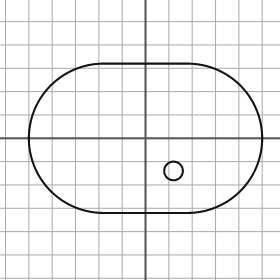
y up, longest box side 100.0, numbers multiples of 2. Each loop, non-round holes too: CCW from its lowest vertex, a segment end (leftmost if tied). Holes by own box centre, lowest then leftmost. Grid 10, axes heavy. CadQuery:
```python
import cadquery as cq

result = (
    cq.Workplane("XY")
    .moveTo(-18.0, -32.0)
    .lineTo(18.0, -32.0)
    .threePointArc((50.0, 0.0), (18.0, 32.0))
    .lineTo(-18.0, 32.0)
    .threePointArc((-50.0, 0.0), (-18.0, -32.0))
    .close()
    .moveTo(12.0, -14.0)
    .circle(4.0)
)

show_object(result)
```